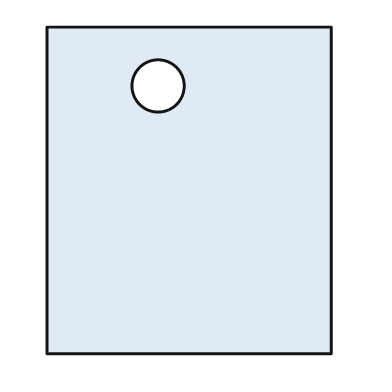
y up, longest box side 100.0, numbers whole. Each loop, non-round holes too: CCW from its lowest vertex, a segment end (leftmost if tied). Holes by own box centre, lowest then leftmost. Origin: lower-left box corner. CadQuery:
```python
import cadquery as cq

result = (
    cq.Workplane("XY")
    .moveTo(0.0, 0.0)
    .lineTo(87.0, 0.0)
    .lineTo(87.0, 100.0)
    .lineTo(0.0, 100.0)
    .close()
    .moveTo(34.0, 82.0)
    .circle(8.0)
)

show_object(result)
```